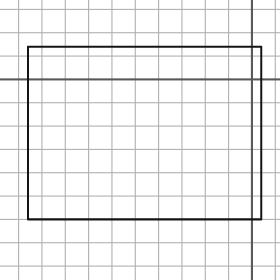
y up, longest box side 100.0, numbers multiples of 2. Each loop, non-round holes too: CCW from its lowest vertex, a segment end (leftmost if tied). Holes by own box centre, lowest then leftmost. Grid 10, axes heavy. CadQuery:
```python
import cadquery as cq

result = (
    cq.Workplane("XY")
    .moveTo(-96.0, -60.0)
    .lineTo(4.0, -60.0)
    .lineTo(4.0, 14.0)
    .lineTo(-96.0, 14.0)
    .close()
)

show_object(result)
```